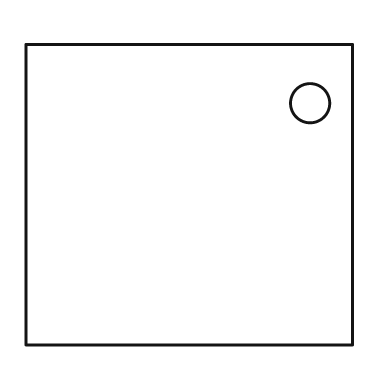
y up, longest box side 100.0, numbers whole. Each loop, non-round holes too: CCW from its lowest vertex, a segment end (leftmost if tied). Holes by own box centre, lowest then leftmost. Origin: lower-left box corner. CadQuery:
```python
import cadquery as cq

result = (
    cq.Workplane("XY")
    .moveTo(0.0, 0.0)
    .lineTo(100.0, 0.0)
    .lineTo(100.0, 92.0)
    .lineTo(0.0, 92.0)
    .close()
    .moveTo(87.0, 74.0)
    .circle(6.0)
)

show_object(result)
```